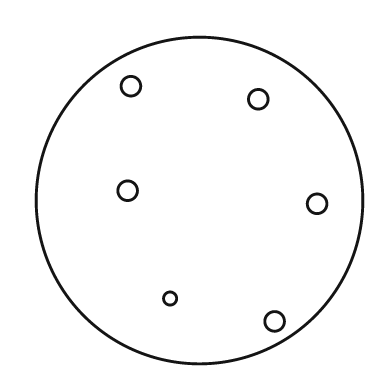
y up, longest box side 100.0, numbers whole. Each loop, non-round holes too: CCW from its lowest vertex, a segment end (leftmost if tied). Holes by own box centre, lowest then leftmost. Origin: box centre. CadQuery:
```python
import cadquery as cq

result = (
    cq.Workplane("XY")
    .moveTo(0.0, 0.0)
    .circle(50.0)
    .moveTo(23.0, -37.0)
    .circle(3.0)
    .moveTo(-9.0, -30.0)
    .circle(2.0)
    .moveTo(36.0, -1.0)
    .circle(3.0)
    .moveTo(-22.0, 3.0)
    .circle(3.0)
    .moveTo(18.0, 31.0)
    .circle(3.0)
    .moveTo(-21.0, 35.0)
    .circle(3.0)
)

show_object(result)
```